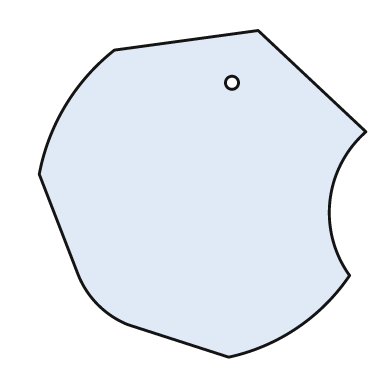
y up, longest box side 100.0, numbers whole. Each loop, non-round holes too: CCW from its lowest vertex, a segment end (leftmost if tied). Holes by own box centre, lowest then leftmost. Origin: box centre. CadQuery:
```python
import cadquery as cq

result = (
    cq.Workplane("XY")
    .moveTo(8.0, -50.0)
    .threePointArc((29.0, -41.0), (45.0, -25.0))
    .threePointArc((39.0, -2.0), (50.0, 19.0))
    .lineTo(17.0, 50.0)
    .lineTo(-27.0, 44.0)
    .threePointArc((-42.0, 27.0), (-50.0, 6.0))
    .lineTo(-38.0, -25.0)
    .threePointArc((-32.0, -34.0), (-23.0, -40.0))
    .close()
    .moveTo(9.0, 34.0)
    .circle(2.0)
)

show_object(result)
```